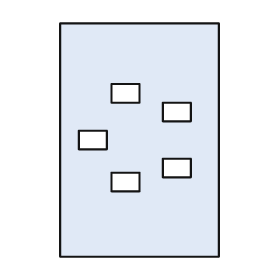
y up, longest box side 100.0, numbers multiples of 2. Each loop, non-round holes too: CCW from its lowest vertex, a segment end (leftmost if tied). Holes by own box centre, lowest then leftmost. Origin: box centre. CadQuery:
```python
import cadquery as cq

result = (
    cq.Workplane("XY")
    .moveTo(-34.0, -50.0)
    .lineTo(34.0, -50.0)
    .lineTo(34.0, 50.0)
    .lineTo(-34.0, 50.0)
    .close()
    .moveTo(-12.0, -22.0)
    .lineTo(0.0, -22.0)
    .lineTo(0.0, -14.0)
    .lineTo(-12.0, -14.0)
    .close()
    .moveTo(10.0, -16.0)
    .lineTo(22.0, -16.0)
    .lineTo(22.0, -8.0)
    .lineTo(10.0, -8.0)
    .close()
    .moveTo(-26.0, -4.0)
    .lineTo(-14.0, -4.0)
    .lineTo(-14.0, 4.0)
    .lineTo(-26.0, 4.0)
    .close()
    .moveTo(10.0, 8.0)
    .lineTo(22.0, 8.0)
    .lineTo(22.0, 16.0)
    .lineTo(10.0, 16.0)
    .close()
    .moveTo(-12.0, 16.0)
    .lineTo(0.0, 16.0)
    .lineTo(0.0, 24.0)
    .lineTo(-12.0, 24.0)
    .close()
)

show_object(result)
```